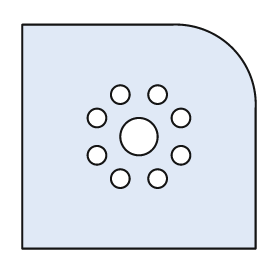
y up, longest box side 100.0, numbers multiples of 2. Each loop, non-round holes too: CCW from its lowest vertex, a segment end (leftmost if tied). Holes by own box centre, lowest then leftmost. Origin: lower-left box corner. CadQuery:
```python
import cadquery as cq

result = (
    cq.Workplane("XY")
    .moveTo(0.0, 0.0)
    .lineTo(100.0, 0.0)
    .lineTo(100.0, 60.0)
    .threePointArc((90.0, 86.0), (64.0, 96.0))
    .lineTo(0.0, 96.0)
    .close()
    .moveTo(42.0, 30.0)
    .circle(4.0)
    .moveTo(58.0, 30.0)
    .circle(4.0)
    .moveTo(32.0, 40.0)
    .circle(4.0)
    .moveTo(68.0, 40.0)
    .circle(4.0)
    .moveTo(50.0, 48.0)
    .circle(8.0)
    .moveTo(32.0, 56.0)
    .circle(4.0)
    .moveTo(68.0, 56.0)
    .circle(4.0)
    .moveTo(42.0, 66.0)
    .circle(4.0)
    .moveTo(58.0, 66.0)
    .circle(4.0)
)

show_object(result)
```